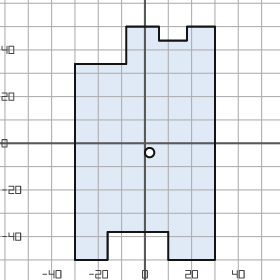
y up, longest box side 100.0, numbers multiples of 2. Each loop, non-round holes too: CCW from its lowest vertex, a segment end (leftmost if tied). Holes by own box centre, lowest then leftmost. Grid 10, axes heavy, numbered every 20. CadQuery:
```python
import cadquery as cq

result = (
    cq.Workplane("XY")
    .moveTo(-30.0, -50.0)
    .lineTo(-16.0, -50.0)
    .lineTo(-16.0, -38.0)
    .lineTo(10.0, -38.0)
    .lineTo(10.0, -50.0)
    .lineTo(30.0, -50.0)
    .lineTo(30.0, 50.0)
    .lineTo(18.0, 50.0)
    .lineTo(18.0, 44.0)
    .lineTo(6.0, 44.0)
    .lineTo(6.0, 50.0)
    .lineTo(-8.0, 50.0)
    .lineTo(-8.0, 34.0)
    .lineTo(-30.0, 34.0)
    .close()
    .moveTo(2.0, -4.0)
    .circle(2.0)
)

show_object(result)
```